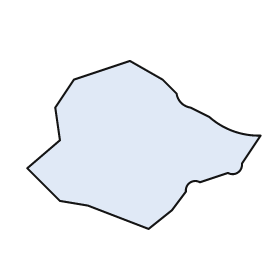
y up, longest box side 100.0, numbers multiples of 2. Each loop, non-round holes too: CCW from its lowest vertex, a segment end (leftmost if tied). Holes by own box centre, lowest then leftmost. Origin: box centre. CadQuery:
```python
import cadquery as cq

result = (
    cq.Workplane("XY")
    .moveTo(2.0, -36.0)
    .lineTo(12.0, -28.0)
    .lineTo(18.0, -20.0)
    .threePointArc((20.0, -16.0), (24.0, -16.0))
    .lineTo(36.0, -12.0)
    .threePointArc((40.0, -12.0), (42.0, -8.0))
    .lineTo(50.0, 4.0)
    .threePointArc((38.0, 6.0), (28.0, 12.0))
    .lineTo(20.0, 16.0)
    .threePointArc((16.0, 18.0), (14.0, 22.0))
    .lineTo(8.0, 28.0)
    .lineTo(-6.0, 36.0)
    .lineTo(-30.0, 28.0)
    .lineTo(-38.0, 16.0)
    .lineTo(-36.0, 2.0)
    .lineTo(-50.0, -10.0)
    .lineTo(-36.0, -24.0)
    .lineTo(-24.0, -26.0)
    .close()
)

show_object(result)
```